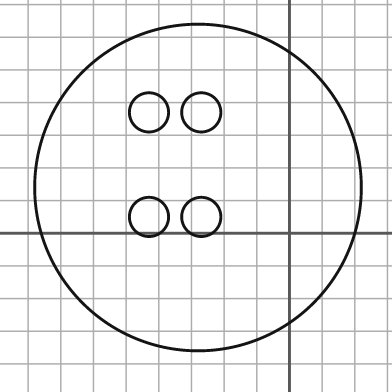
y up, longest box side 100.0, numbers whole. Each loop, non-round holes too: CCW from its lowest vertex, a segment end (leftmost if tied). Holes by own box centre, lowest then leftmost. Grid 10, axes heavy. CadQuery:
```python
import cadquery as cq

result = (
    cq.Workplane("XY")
    .moveTo(-28.0, 14.0)
    .circle(50.0)
    .moveTo(-43.0, 5.0)
    .circle(6.0)
    .moveTo(-27.0, 5.0)
    .circle(6.0)
    .moveTo(-43.0, 37.0)
    .circle(6.0)
    .moveTo(-27.0, 37.0)
    .circle(6.0)
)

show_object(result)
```